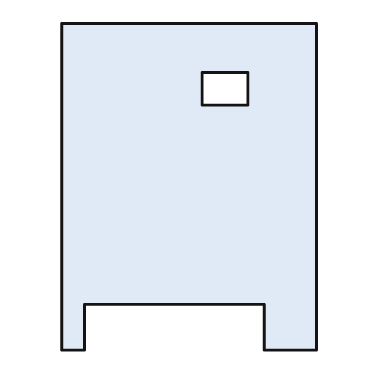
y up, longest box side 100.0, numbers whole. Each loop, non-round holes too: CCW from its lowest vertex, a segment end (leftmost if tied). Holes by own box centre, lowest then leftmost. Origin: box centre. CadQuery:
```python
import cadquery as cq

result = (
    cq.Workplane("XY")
    .moveTo(-39.0, -50.0)
    .lineTo(-32.0, -50.0)
    .lineTo(-32.0, -36.0)
    .lineTo(23.0, -36.0)
    .lineTo(23.0, -50.0)
    .lineTo(39.0, -50.0)
    .lineTo(39.0, 50.0)
    .lineTo(-39.0, 50.0)
    .close()
    .moveTo(4.0, 25.0)
    .lineTo(18.0, 25.0)
    .lineTo(18.0, 35.0)
    .lineTo(4.0, 35.0)
    .close()
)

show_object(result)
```